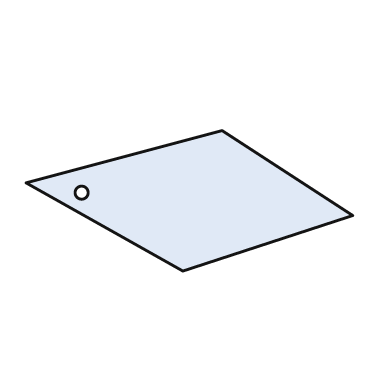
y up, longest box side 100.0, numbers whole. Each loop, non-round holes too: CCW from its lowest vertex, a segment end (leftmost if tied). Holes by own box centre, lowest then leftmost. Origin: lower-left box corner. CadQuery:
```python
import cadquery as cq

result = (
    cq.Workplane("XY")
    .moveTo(48.0, 0.0)
    .lineTo(100.0, 17.0)
    .lineTo(60.0, 43.0)
    .lineTo(0.0, 27.0)
    .close()
    .moveTo(17.0, 24.0)
    .circle(2.0)
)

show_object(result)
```